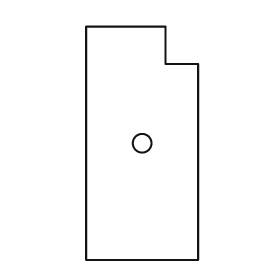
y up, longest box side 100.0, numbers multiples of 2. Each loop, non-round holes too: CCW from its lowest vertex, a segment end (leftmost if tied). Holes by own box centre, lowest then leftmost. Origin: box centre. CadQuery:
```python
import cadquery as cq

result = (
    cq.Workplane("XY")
    .moveTo(-24.0, -50.0)
    .lineTo(24.0, -50.0)
    .lineTo(24.0, 34.0)
    .lineTo(10.0, 34.0)
    .lineTo(10.0, 50.0)
    .lineTo(-24.0, 50.0)
    .close()
    .moveTo(0.0, 0.0)
    .circle(4.0)
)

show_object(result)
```